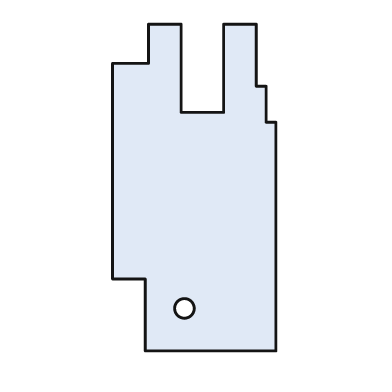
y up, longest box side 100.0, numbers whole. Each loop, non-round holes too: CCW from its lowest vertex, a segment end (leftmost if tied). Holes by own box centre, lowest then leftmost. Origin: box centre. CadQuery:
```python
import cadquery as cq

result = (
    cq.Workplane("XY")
    .moveTo(-15.0, -50.0)
    .lineTo(25.0, -50.0)
    .lineTo(25.0, 20.0)
    .lineTo(22.0, 20.0)
    .lineTo(22.0, 31.0)
    .lineTo(19.0, 31.0)
    .lineTo(19.0, 50.0)
    .lineTo(9.0, 50.0)
    .lineTo(9.0, 23.0)
    .lineTo(-4.0, 23.0)
    .lineTo(-4.0, 50.0)
    .lineTo(-14.0, 50.0)
    .lineTo(-14.0, 38.0)
    .lineTo(-25.0, 38.0)
    .lineTo(-25.0, -28.0)
    .lineTo(-15.0, -28.0)
    .close()
    .moveTo(-3.0, -37.0)
    .circle(3.0)
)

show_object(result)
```